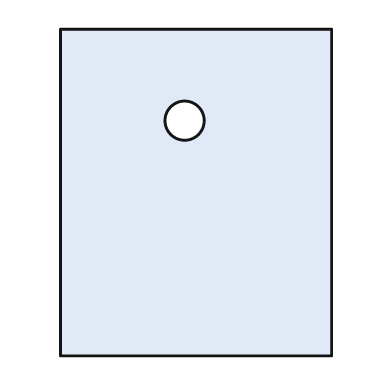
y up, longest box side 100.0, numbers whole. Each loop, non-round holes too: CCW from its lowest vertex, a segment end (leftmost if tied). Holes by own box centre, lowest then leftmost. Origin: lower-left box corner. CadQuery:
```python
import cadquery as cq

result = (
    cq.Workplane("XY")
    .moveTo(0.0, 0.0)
    .lineTo(83.0, 0.0)
    .lineTo(83.0, 100.0)
    .lineTo(0.0, 100.0)
    .close()
    .moveTo(38.0, 72.0)
    .circle(6.0)
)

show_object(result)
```